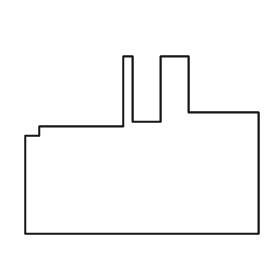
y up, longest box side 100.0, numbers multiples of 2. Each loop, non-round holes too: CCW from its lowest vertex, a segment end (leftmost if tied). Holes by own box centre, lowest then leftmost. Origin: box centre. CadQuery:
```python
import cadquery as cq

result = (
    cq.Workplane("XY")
    .moveTo(-50.0, -38.0)
    .lineTo(50.0, -38.0)
    .lineTo(50.0, 14.0)
    .lineTo(20.0, 14.0)
    .lineTo(20.0, 38.0)
    .lineTo(8.0, 38.0)
    .lineTo(8.0, 10.0)
    .lineTo(-4.0, 10.0)
    .lineTo(-4.0, 38.0)
    .lineTo(-8.0, 38.0)
    .lineTo(-8.0, 8.0)
    .lineTo(-44.0, 8.0)
    .lineTo(-44.0, 4.0)
    .lineTo(-50.0, 4.0)
    .close()
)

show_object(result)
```